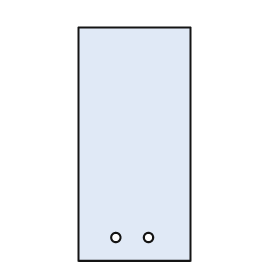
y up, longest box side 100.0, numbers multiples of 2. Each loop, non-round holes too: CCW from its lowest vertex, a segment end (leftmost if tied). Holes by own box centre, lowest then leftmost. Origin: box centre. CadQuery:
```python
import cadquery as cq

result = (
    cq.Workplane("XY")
    .moveTo(-24.0, -50.0)
    .lineTo(24.0, -50.0)
    .lineTo(24.0, 50.0)
    .lineTo(-24.0, 50.0)
    .close()
    .moveTo(-8.0, -40.0)
    .circle(2.0)
    .moveTo(6.0, -40.0)
    .circle(2.0)
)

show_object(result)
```